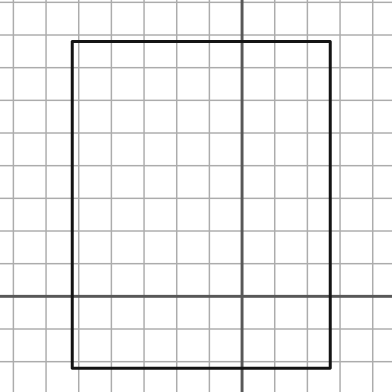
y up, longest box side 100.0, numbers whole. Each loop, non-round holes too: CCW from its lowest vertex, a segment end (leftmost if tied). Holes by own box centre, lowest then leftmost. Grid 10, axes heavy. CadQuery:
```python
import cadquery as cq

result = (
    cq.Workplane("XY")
    .moveTo(-52.0, -22.0)
    .lineTo(27.0, -22.0)
    .lineTo(27.0, 78.0)
    .lineTo(-52.0, 78.0)
    .close()
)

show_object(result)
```